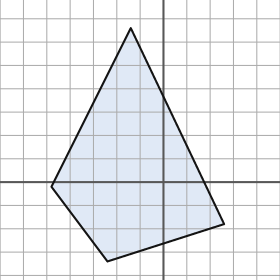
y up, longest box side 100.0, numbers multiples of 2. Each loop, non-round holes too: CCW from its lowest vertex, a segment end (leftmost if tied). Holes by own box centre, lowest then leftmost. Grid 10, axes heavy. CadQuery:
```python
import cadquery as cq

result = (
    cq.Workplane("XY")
    .moveTo(-24.0, -34.0)
    .lineTo(26.0, -18.0)
    .lineTo(-14.0, 66.0)
    .lineTo(-48.0, -2.0)
    .close()
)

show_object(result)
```